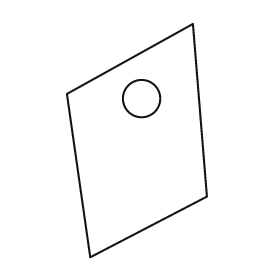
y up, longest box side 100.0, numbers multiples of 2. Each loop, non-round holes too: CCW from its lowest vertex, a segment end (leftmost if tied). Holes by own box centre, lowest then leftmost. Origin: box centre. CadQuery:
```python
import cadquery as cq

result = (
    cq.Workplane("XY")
    .moveTo(-20.0, -50.0)
    .lineTo(30.0, -24.0)
    .lineTo(24.0, 50.0)
    .lineTo(-30.0, 20.0)
    .close()
    .moveTo(2.0, 18.0)
    .circle(8.0)
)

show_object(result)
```